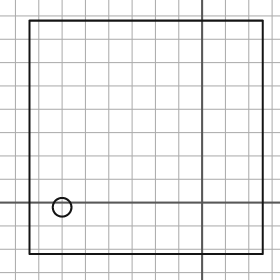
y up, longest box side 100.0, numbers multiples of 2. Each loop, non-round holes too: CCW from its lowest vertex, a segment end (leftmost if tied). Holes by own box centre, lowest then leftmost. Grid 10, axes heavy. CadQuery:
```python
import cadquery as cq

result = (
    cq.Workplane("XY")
    .moveTo(-74.0, -22.0)
    .lineTo(26.0, -22.0)
    .lineTo(26.0, 78.0)
    .lineTo(-74.0, 78.0)
    .close()
    .moveTo(-60.0, -2.0)
    .circle(4.0)
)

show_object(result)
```